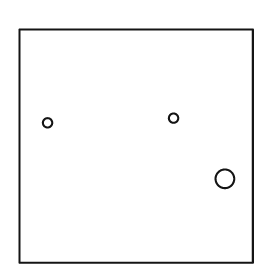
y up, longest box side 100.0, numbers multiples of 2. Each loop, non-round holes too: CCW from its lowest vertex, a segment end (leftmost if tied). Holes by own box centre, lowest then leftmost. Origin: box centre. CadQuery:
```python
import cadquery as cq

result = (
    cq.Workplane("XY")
    .moveTo(-50.0, -50.0)
    .lineTo(50.0, -50.0)
    .lineTo(50.0, 50.0)
    .lineTo(-50.0, 50.0)
    .close()
    .moveTo(38.0, -14.0)
    .circle(4.0)
    .moveTo(-38.0, 10.0)
    .circle(2.0)
    .moveTo(16.0, 12.0)
    .circle(2.0)
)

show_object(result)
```